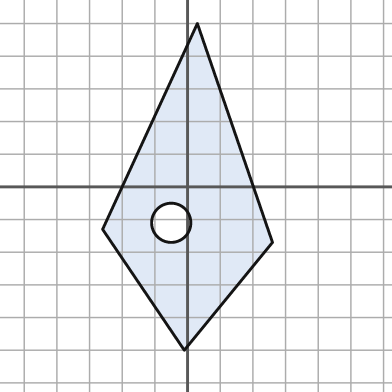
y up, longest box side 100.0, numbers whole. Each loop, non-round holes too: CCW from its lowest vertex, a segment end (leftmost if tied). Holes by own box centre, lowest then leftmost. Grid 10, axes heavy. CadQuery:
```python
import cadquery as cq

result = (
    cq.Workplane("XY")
    .moveTo(-1.0, -50.0)
    .lineTo(26.0, -17.0)
    .lineTo(3.0, 50.0)
    .lineTo(-26.0, -13.0)
    .close()
    .moveTo(-5.0, -11.0)
    .circle(6.0)
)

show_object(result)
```